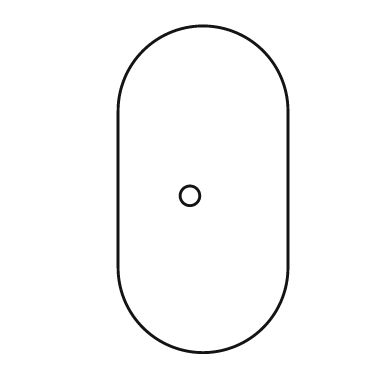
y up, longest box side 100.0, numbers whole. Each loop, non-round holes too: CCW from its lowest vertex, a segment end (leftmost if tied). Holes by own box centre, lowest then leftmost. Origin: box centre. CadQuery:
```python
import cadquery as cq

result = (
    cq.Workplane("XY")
    .moveTo(-26.0, -24.0)
    .threePointArc((0.0, -50.0), (26.0, -24.0))
    .lineTo(26.0, 24.0)
    .threePointArc((0.0, 50.0), (-26.0, 24.0))
    .close()
    .moveTo(-4.0, -2.0)
    .circle(3.0)
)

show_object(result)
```